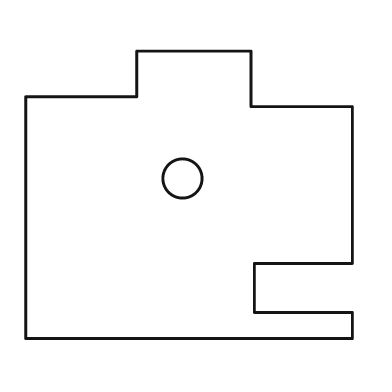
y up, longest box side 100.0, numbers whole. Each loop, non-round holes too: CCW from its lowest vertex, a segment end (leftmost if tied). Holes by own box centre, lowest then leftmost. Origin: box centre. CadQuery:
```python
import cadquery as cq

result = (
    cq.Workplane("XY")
    .moveTo(-50.0, -44.0)
    .lineTo(50.0, -44.0)
    .lineTo(50.0, -36.0)
    .lineTo(20.0, -36.0)
    .lineTo(20.0, -21.0)
    .lineTo(50.0, -21.0)
    .lineTo(50.0, 27.0)
    .lineTo(19.0, 27.0)
    .lineTo(19.0, 44.0)
    .lineTo(-16.0, 44.0)
    .lineTo(-16.0, 30.0)
    .lineTo(-50.0, 30.0)
    .close()
    .moveTo(-2.0, 5.0)
    .circle(6.0)
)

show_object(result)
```